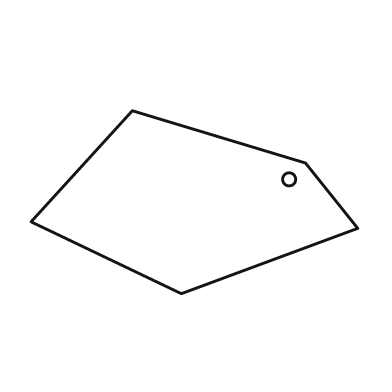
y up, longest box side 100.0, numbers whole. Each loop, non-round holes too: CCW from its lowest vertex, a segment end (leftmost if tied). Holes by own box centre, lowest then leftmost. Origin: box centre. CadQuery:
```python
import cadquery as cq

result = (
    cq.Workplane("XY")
    .moveTo(-4.0, -28.0)
    .lineTo(50.0, -8.0)
    .lineTo(34.0, 12.0)
    .lineTo(-19.0, 28.0)
    .lineTo(-50.0, -6.0)
    .close()
    .moveTo(29.0, 7.0)
    .circle(2.0)
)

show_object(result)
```